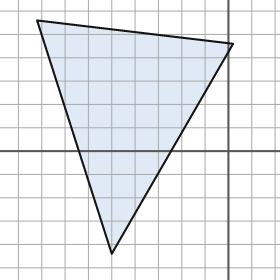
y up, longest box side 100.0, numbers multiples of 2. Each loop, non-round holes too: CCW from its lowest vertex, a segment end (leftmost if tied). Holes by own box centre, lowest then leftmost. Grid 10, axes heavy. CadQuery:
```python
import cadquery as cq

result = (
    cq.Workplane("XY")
    .moveTo(-50.0, -44.0)
    .lineTo(2.0, 46.0)
    .lineTo(-82.0, 56.0)
    .close()
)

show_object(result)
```